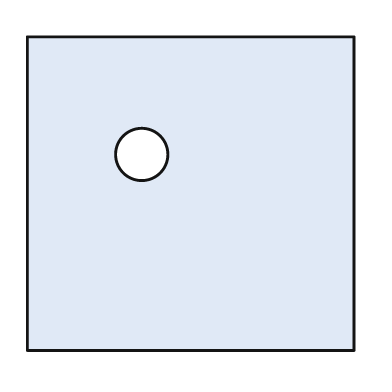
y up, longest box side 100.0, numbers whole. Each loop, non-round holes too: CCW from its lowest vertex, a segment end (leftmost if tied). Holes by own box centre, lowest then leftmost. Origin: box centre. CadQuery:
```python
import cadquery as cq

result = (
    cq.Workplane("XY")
    .moveTo(-50.0, -48.0)
    .lineTo(50.0, -48.0)
    .lineTo(50.0, 48.0)
    .lineTo(-50.0, 48.0)
    .close()
    .moveTo(-15.0, 12.0)
    .circle(8.0)
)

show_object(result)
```